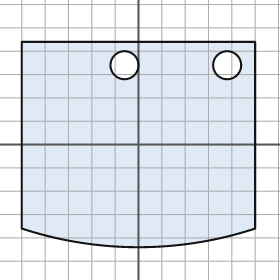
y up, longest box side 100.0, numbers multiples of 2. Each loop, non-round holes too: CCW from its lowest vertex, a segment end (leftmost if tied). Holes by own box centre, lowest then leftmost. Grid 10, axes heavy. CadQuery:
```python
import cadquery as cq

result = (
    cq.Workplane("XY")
    .moveTo(-50.0, -36.0)
    .threePointArc((0.0, -44.0), (50.0, -36.0))
    .lineTo(50.0, 44.0)
    .lineTo(-50.0, 44.0)
    .close()
    .moveTo(-6.0, 34.0)
    .circle(6.0)
    .moveTo(38.0, 34.0)
    .circle(6.0)
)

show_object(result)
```